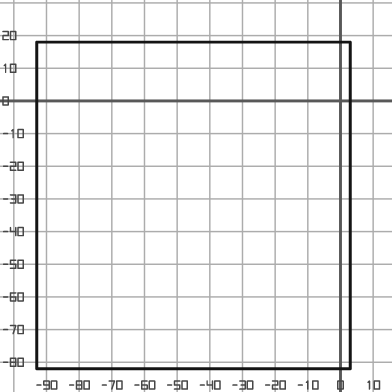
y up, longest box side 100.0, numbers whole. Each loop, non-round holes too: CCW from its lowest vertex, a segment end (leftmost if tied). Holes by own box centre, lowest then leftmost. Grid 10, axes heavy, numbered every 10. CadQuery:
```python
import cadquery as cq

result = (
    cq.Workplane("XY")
    .moveTo(-93.0, -82.0)
    .lineTo(3.0, -82.0)
    .lineTo(3.0, 18.0)
    .lineTo(-93.0, 18.0)
    .close()
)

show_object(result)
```